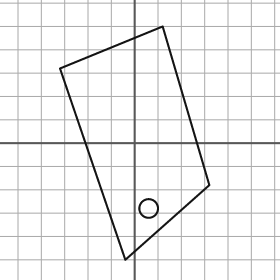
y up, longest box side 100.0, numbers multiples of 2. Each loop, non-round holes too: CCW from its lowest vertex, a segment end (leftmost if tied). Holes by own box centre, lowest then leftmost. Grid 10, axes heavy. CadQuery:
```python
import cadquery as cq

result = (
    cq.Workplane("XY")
    .moveTo(-4.0, -50.0)
    .lineTo(32.0, -18.0)
    .lineTo(12.0, 50.0)
    .lineTo(-32.0, 32.0)
    .close()
    .moveTo(6.0, -28.0)
    .circle(4.0)
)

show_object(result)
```